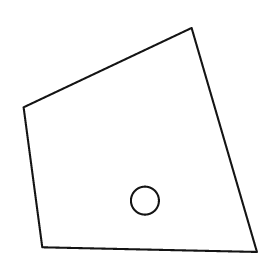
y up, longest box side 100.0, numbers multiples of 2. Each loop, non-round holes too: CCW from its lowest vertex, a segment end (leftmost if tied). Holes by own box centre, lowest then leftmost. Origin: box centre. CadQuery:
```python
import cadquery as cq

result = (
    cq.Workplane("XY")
    .moveTo(50.0, -48.0)
    .lineTo(22.0, 48.0)
    .lineTo(-50.0, 14.0)
    .lineTo(-42.0, -46.0)
    .close()
    .moveTo(2.0, -26.0)
    .circle(6.0)
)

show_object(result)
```